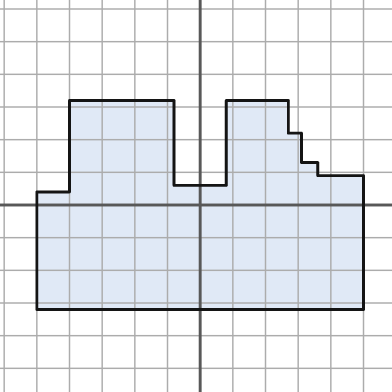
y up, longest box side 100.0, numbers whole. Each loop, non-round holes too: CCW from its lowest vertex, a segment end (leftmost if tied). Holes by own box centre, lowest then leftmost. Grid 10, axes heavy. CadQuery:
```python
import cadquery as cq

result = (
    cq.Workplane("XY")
    .moveTo(-50.0, -32.0)
    .lineTo(50.0, -32.0)
    .lineTo(50.0, 9.0)
    .lineTo(36.0, 9.0)
    .lineTo(36.0, 13.0)
    .lineTo(31.0, 13.0)
    .lineTo(31.0, 22.0)
    .lineTo(27.0, 22.0)
    .lineTo(27.0, 32.0)
    .lineTo(8.0, 32.0)
    .lineTo(8.0, 6.0)
    .lineTo(-8.0, 6.0)
    .lineTo(-8.0, 32.0)
    .lineTo(-40.0, 32.0)
    .lineTo(-40.0, 4.0)
    .lineTo(-50.0, 4.0)
    .close()
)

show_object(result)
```